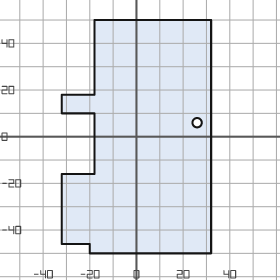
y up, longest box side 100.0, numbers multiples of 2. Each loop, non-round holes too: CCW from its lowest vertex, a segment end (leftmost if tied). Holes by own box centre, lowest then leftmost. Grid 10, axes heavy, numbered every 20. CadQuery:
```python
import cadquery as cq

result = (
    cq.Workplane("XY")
    .moveTo(-20.0, -50.0)
    .lineTo(32.0, -50.0)
    .lineTo(32.0, 50.0)
    .lineTo(-18.0, 50.0)
    .lineTo(-18.0, 18.0)
    .lineTo(-32.0, 18.0)
    .lineTo(-32.0, 10.0)
    .lineTo(-18.0, 10.0)
    .lineTo(-18.0, -16.0)
    .lineTo(-32.0, -16.0)
    .lineTo(-32.0, -46.0)
    .lineTo(-20.0, -46.0)
    .close()
    .moveTo(26.0, 6.0)
    .circle(2.0)
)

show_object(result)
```